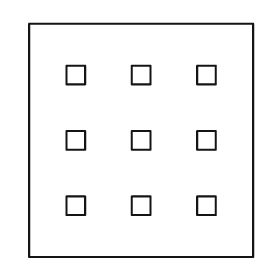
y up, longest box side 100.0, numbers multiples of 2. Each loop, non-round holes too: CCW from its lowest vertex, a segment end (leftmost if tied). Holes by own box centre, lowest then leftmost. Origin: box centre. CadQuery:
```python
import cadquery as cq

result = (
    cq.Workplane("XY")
    .moveTo(-48.0, -50.0)
    .lineTo(48.0, -50.0)
    .lineTo(48.0, 50.0)
    .lineTo(-48.0, 50.0)
    .close()
    .moveTo(-32.0, -32.0)
    .lineTo(-24.0, -32.0)
    .lineTo(-24.0, -24.0)
    .lineTo(-32.0, -24.0)
    .close()
    .moveTo(-4.0, -32.0)
    .lineTo(4.0, -32.0)
    .lineTo(4.0, -24.0)
    .lineTo(-4.0, -24.0)
    .close()
    .moveTo(24.0, -32.0)
    .lineTo(32.0, -32.0)
    .lineTo(32.0, -24.0)
    .lineTo(24.0, -24.0)
    .close()
    .moveTo(-32.0, -4.0)
    .lineTo(-24.0, -4.0)
    .lineTo(-24.0, 4.0)
    .lineTo(-32.0, 4.0)
    .close()
    .moveTo(-4.0, -4.0)
    .lineTo(4.0, -4.0)
    .lineTo(4.0, 4.0)
    .lineTo(-4.0, 4.0)
    .close()
    .moveTo(24.0, -4.0)
    .lineTo(32.0, -4.0)
    .lineTo(32.0, 4.0)
    .lineTo(24.0, 4.0)
    .close()
    .moveTo(-32.0, 24.0)
    .lineTo(-24.0, 24.0)
    .lineTo(-24.0, 32.0)
    .lineTo(-32.0, 32.0)
    .close()
    .moveTo(-4.0, 24.0)
    .lineTo(4.0, 24.0)
    .lineTo(4.0, 32.0)
    .lineTo(-4.0, 32.0)
    .close()
    .moveTo(24.0, 24.0)
    .lineTo(32.0, 24.0)
    .lineTo(32.0, 32.0)
    .lineTo(24.0, 32.0)
    .close()
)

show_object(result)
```